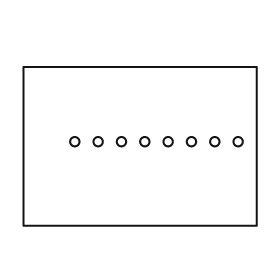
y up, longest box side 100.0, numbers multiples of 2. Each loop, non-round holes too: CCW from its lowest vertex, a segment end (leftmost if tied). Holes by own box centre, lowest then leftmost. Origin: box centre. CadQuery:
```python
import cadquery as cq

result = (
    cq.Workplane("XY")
    .moveTo(-50.0, -34.0)
    .lineTo(50.0, -34.0)
    .lineTo(50.0, 34.0)
    .lineTo(-50.0, 34.0)
    .close()
    .moveTo(-28.0, 2.0)
    .circle(2.0)
    .moveTo(-18.0, 2.0)
    .circle(2.0)
    .moveTo(-8.0, 2.0)
    .circle(2.0)
    .moveTo(2.0, 2.0)
    .circle(2.0)
    .moveTo(12.0, 2.0)
    .circle(2.0)
    .moveTo(22.0, 2.0)
    .circle(2.0)
    .moveTo(32.0, 2.0)
    .circle(2.0)
    .moveTo(42.0, 2.0)
    .circle(2.0)
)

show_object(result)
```